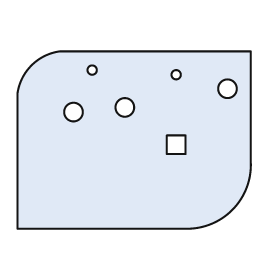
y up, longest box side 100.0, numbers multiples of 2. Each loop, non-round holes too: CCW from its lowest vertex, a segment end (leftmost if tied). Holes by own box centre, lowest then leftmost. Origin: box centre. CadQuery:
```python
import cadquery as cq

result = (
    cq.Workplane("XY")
    .moveTo(-50.0, -38.0)
    .lineTo(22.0, -38.0)
    .threePointArc((42.0, -30.0), (50.0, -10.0))
    .lineTo(50.0, 38.0)
    .lineTo(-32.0, 38.0)
    .threePointArc((-44.0, 32.0), (-50.0, 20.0))
    .close()
    .moveTo(14.0, -6.0)
    .lineTo(22.0, -6.0)
    .lineTo(22.0, 2.0)
    .lineTo(14.0, 2.0)
    .close()
    .moveTo(-26.0, 12.0)
    .circle(4.0)
    .moveTo(-4.0, 14.0)
    .circle(4.0)
    .moveTo(40.0, 22.0)
    .circle(4.0)
    .moveTo(18.0, 28.0)
    .circle(2.0)
    .moveTo(-18.0, 30.0)
    .circle(2.0)
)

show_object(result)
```